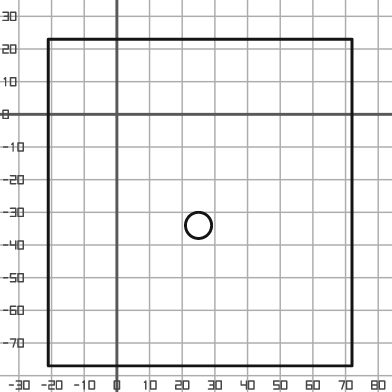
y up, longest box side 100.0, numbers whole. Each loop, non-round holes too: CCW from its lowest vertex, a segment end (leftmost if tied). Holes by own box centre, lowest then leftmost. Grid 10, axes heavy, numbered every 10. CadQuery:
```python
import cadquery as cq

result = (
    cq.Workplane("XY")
    .moveTo(-21.0, -77.0)
    .lineTo(72.0, -77.0)
    .lineTo(72.0, 23.0)
    .lineTo(-21.0, 23.0)
    .close()
    .moveTo(25.0, -34.0)
    .circle(4.0)
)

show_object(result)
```